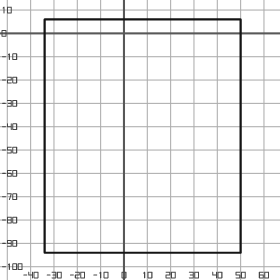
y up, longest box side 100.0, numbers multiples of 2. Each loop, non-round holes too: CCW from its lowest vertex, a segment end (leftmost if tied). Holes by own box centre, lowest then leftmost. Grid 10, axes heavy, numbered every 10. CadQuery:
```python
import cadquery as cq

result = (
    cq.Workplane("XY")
    .moveTo(-34.0, -94.0)
    .lineTo(50.0, -94.0)
    .lineTo(50.0, 6.0)
    .lineTo(-34.0, 6.0)
    .close()
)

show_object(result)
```